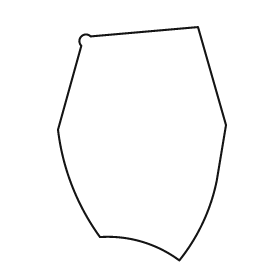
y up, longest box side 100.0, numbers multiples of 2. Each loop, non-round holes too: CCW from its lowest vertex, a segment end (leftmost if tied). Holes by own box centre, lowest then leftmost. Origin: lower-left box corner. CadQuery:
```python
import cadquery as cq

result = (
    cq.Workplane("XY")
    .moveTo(52.0, 0.0)
    .threePointArc((62.0, 16.0), (68.0, 34.0))
    .lineTo(72.0, 58.0)
    .lineTo(60.0, 100.0)
    .lineTo(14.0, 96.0)
    .threePointArc((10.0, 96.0), (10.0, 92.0))
    .lineTo(0.0, 56.0)
    .threePointArc((6.0, 32.0), (18.0, 10.0))
    .threePointArc((36.0, 8.0), (52.0, 0.0))
    .close()
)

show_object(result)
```